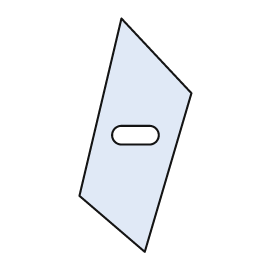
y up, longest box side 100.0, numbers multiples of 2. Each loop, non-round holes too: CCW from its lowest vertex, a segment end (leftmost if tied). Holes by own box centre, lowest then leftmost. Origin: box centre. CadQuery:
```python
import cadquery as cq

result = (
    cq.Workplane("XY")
    .moveTo(4.0, -50.0)
    .lineTo(24.0, 18.0)
    .lineTo(-6.0, 50.0)
    .lineTo(-24.0, -26.0)
    .close()
    .moveTo(-6.0, -4.0)
    .lineTo(6.0, -4.0)
    .threePointArc((10.0, 0.0), (6.0, 4.0))
    .lineTo(-6.0, 4.0)
    .threePointArc((-10.0, 0.0), (-6.0, -4.0))
    .close()
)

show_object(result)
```